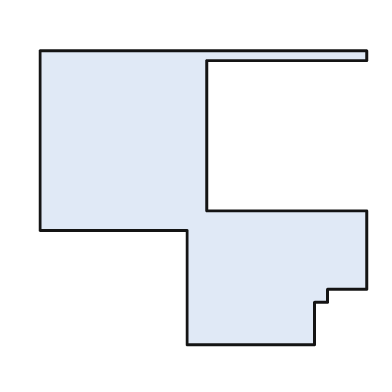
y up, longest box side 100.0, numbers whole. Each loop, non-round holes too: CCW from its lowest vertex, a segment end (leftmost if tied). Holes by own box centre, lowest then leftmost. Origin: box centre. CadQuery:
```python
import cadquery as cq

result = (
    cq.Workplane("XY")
    .moveTo(-5.0, -45.0)
    .lineTo(34.0, -45.0)
    .lineTo(34.0, -32.0)
    .lineTo(38.0, -32.0)
    .lineTo(38.0, -28.0)
    .lineTo(50.0, -28.0)
    .lineTo(50.0, -4.0)
    .lineTo(1.0, -4.0)
    .lineTo(1.0, 42.0)
    .lineTo(50.0, 42.0)
    .lineTo(50.0, 45.0)
    .lineTo(-50.0, 45.0)
    .lineTo(-50.0, -10.0)
    .lineTo(-5.0, -10.0)
    .close()
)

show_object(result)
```